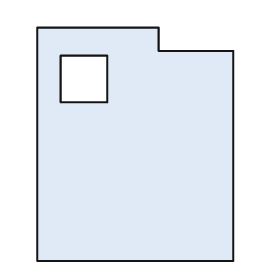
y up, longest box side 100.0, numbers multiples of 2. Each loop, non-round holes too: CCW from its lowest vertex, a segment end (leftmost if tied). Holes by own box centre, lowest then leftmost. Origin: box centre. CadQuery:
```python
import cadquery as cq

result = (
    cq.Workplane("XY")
    .moveTo(-42.0, -50.0)
    .lineTo(42.0, -50.0)
    .lineTo(42.0, 40.0)
    .lineTo(10.0, 40.0)
    .lineTo(10.0, 50.0)
    .lineTo(-42.0, 50.0)
    .close()
    .moveTo(-32.0, 18.0)
    .lineTo(-12.0, 18.0)
    .lineTo(-12.0, 38.0)
    .lineTo(-32.0, 38.0)
    .close()
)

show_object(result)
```